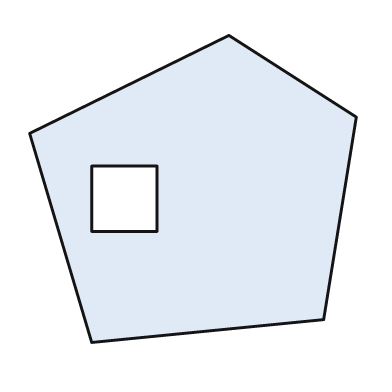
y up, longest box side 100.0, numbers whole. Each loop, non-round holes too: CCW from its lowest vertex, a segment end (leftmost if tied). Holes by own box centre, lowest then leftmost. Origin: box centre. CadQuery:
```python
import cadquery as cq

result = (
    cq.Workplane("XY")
    .moveTo(-31.0, -47.0)
    .lineTo(40.0, -40.0)
    .lineTo(50.0, 22.0)
    .lineTo(11.0, 47.0)
    .lineTo(-50.0, 17.0)
    .close()
    .moveTo(-31.0, -13.0)
    .lineTo(-11.0, -13.0)
    .lineTo(-11.0, 7.0)
    .lineTo(-31.0, 7.0)
    .close()
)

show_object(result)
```